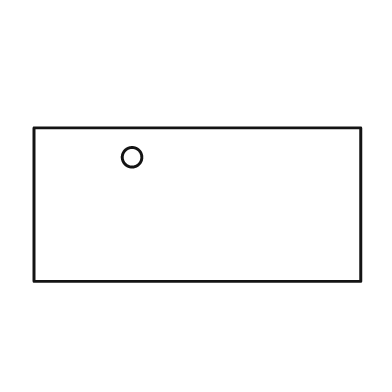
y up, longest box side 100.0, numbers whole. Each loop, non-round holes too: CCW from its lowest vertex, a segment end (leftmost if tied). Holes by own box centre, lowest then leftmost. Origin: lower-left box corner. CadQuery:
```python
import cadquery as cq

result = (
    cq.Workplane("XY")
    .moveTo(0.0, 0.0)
    .lineTo(100.0, 0.0)
    .lineTo(100.0, 47.0)
    .lineTo(0.0, 47.0)
    .close()
    .moveTo(30.0, 38.0)
    .circle(3.0)
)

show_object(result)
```